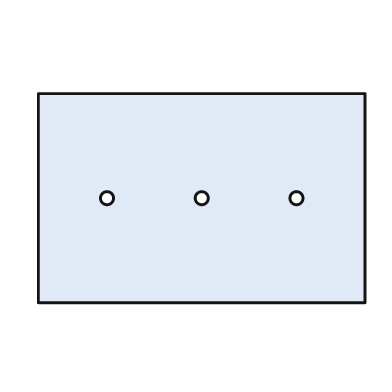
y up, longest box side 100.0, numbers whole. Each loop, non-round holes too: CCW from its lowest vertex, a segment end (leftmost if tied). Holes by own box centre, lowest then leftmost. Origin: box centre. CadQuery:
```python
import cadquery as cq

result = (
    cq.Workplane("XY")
    .moveTo(-50.0, -32.0)
    .lineTo(50.0, -32.0)
    .lineTo(50.0, 32.0)
    .lineTo(-50.0, 32.0)
    .close()
    .moveTo(-29.0, 0.0)
    .circle(2.0)
    .moveTo(0.0, 0.0)
    .circle(2.0)
    .moveTo(29.0, 0.0)
    .circle(2.0)
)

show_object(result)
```